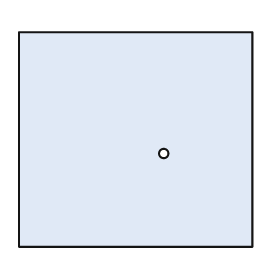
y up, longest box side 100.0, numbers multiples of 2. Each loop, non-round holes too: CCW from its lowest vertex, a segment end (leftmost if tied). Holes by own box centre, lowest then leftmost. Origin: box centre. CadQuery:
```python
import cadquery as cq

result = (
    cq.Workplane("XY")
    .moveTo(-50.0, -46.0)
    .lineTo(50.0, -46.0)
    .lineTo(50.0, 46.0)
    .lineTo(-50.0, 46.0)
    .close()
    .moveTo(12.0, -6.0)
    .circle(2.0)
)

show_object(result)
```